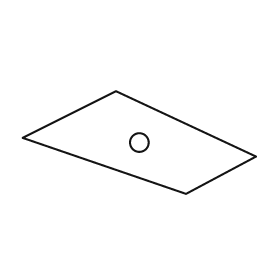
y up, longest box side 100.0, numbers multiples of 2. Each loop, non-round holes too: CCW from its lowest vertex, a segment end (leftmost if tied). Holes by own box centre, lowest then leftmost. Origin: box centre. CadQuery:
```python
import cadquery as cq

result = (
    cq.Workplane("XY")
    .moveTo(20.0, -22.0)
    .lineTo(50.0, -6.0)
    .lineTo(-10.0, 22.0)
    .lineTo(-50.0, 2.0)
    .close()
    .moveTo(0.0, 0.0)
    .circle(4.0)
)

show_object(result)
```